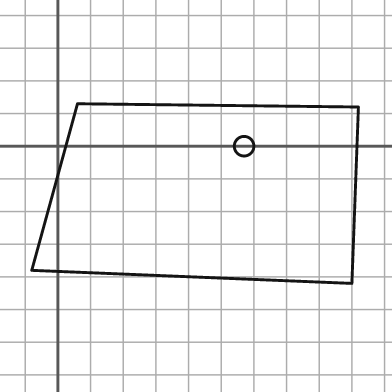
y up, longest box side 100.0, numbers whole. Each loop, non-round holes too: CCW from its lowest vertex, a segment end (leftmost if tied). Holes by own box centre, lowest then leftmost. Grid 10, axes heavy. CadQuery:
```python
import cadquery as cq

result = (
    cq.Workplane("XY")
    .moveTo(90.0, -42.0)
    .lineTo(92.0, 12.0)
    .lineTo(6.0, 13.0)
    .lineTo(-8.0, -38.0)
    .close()
    .moveTo(57.0, 0.0)
    .circle(3.0)
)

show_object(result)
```